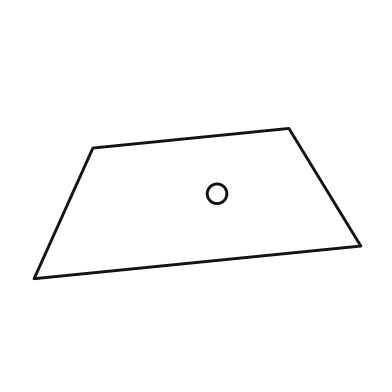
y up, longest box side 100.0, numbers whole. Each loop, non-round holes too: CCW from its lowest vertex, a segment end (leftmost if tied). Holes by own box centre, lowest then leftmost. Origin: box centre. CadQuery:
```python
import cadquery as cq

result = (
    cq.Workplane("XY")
    .moveTo(-50.0, -23.0)
    .lineTo(50.0, -13.0)
    .lineTo(28.0, 23.0)
    .lineTo(-32.0, 17.0)
    .close()
    .moveTo(6.0, 3.0)
    .circle(3.0)
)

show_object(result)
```